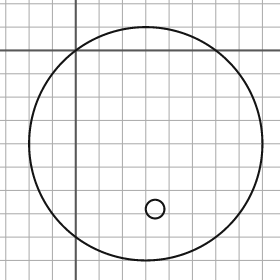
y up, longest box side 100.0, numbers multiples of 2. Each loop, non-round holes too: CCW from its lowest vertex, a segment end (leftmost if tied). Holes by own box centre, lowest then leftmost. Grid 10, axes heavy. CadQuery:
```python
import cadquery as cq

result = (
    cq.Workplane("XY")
    .moveTo(30.0, -40.0)
    .circle(50.0)
    .moveTo(34.0, -68.0)
    .circle(4.0)
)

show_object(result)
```